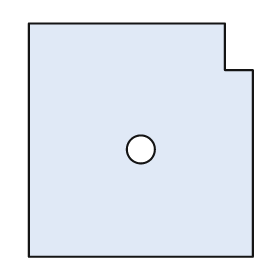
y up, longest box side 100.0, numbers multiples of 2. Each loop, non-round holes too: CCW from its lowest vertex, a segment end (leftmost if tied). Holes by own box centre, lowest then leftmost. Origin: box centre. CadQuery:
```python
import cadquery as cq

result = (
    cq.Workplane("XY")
    .moveTo(-48.0, -50.0)
    .lineTo(48.0, -50.0)
    .lineTo(48.0, 30.0)
    .lineTo(36.0, 30.0)
    .lineTo(36.0, 50.0)
    .lineTo(-48.0, 50.0)
    .close()
    .moveTo(0.0, -4.0)
    .circle(6.0)
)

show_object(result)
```